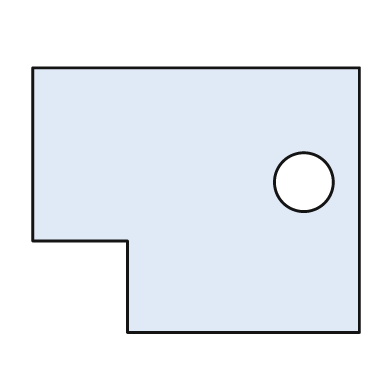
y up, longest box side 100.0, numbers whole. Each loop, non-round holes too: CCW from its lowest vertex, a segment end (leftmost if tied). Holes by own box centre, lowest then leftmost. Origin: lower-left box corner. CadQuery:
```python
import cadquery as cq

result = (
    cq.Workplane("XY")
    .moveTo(29.0, 0.0)
    .lineTo(100.0, 0.0)
    .lineTo(100.0, 81.0)
    .lineTo(0.0, 81.0)
    .lineTo(0.0, 28.0)
    .lineTo(29.0, 28.0)
    .close()
    .moveTo(83.0, 46.0)
    .circle(9.0)
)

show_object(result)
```